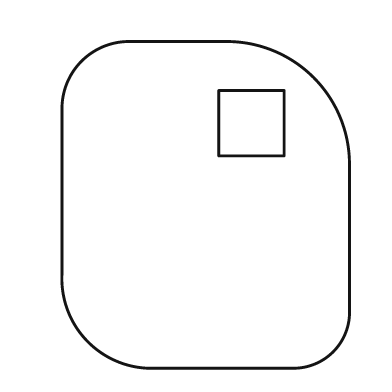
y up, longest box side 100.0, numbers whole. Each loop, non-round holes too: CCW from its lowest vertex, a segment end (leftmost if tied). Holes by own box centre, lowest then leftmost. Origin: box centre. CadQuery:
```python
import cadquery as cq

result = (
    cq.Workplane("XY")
    .moveTo(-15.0, -50.0)
    .lineTo(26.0, -50.0)
    .threePointArc((39.0, -45.0), (44.0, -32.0))
    .lineTo(44.0, 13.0)
    .threePointArc((33.0, 39.0), (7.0, 50.0))
    .lineTo(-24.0, 50.0)
    .threePointArc((-38.0, 44.0), (-44.0, 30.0))
    .lineTo(-44.0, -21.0)
    .threePointArc((-36.0, -42.0), (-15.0, -50.0))
    .close()
    .moveTo(4.0, 15.0)
    .lineTo(24.0, 15.0)
    .lineTo(24.0, 35.0)
    .lineTo(4.0, 35.0)
    .close()
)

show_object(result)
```